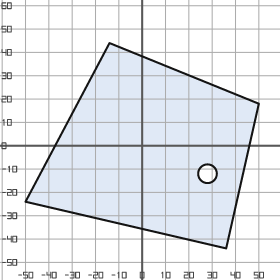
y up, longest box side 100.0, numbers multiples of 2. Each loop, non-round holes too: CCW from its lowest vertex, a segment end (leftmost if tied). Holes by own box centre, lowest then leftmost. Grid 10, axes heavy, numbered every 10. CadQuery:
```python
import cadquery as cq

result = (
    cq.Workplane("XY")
    .moveTo(36.0, -44.0)
    .lineTo(50.0, 18.0)
    .lineTo(-14.0, 44.0)
    .lineTo(-50.0, -24.0)
    .close()
    .moveTo(28.0, -12.0)
    .circle(4.0)
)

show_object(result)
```